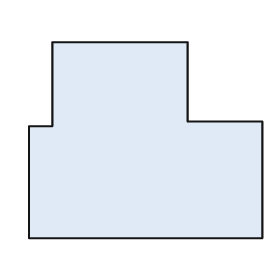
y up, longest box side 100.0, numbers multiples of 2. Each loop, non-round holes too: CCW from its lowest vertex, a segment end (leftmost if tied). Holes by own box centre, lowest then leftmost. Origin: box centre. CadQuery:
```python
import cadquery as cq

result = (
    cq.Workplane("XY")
    .moveTo(-50.0, -42.0)
    .lineTo(50.0, -42.0)
    .lineTo(50.0, 8.0)
    .lineTo(18.0, 8.0)
    .lineTo(18.0, 42.0)
    .lineTo(-40.0, 42.0)
    .lineTo(-40.0, 6.0)
    .lineTo(-50.0, 6.0)
    .close()
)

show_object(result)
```